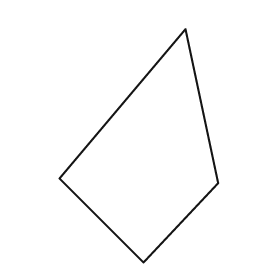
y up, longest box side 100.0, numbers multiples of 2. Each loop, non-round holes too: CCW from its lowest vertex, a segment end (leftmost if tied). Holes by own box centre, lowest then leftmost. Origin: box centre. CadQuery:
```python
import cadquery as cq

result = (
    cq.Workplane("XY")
    .moveTo(2.0, -50.0)
    .lineTo(34.0, -16.0)
    .lineTo(20.0, 50.0)
    .lineTo(-34.0, -14.0)
    .close()
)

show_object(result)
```